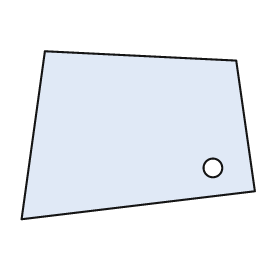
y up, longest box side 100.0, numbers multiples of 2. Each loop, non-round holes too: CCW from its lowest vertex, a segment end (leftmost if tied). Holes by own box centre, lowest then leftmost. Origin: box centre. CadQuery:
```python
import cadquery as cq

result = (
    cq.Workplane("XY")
    .moveTo(-50.0, -36.0)
    .lineTo(50.0, -24.0)
    .lineTo(42.0, 32.0)
    .lineTo(-40.0, 36.0)
    .close()
    .moveTo(32.0, -14.0)
    .circle(4.0)
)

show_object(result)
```